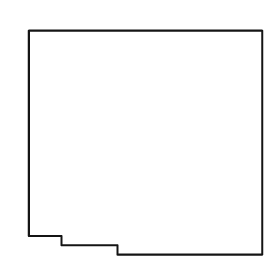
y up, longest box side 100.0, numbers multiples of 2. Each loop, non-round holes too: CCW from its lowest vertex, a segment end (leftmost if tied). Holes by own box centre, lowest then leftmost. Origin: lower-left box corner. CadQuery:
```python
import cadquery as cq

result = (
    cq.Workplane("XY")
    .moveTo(38.0, 0.0)
    .lineTo(100.0, 0.0)
    .lineTo(100.0, 96.0)
    .lineTo(0.0, 96.0)
    .lineTo(0.0, 8.0)
    .lineTo(14.0, 8.0)
    .lineTo(14.0, 4.0)
    .lineTo(38.0, 4.0)
    .close()
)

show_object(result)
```